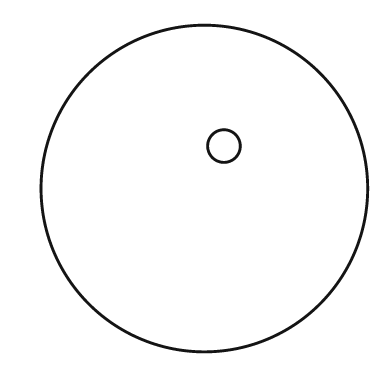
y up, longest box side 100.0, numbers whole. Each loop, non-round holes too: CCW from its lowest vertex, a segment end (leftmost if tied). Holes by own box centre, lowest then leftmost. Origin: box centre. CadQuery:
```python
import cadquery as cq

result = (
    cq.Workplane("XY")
    .moveTo(0.0, 0.0)
    .circle(50.0)
    .moveTo(6.0, 13.0)
    .circle(5.0)
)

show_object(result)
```